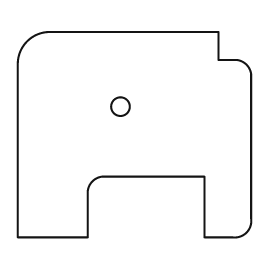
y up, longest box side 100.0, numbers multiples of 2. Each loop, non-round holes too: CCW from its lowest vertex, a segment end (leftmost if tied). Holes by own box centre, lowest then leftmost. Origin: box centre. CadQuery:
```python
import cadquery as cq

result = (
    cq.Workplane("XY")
    .moveTo(-50.0, -44.0)
    .lineTo(-20.0, -44.0)
    .lineTo(-20.0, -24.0)
    .threePointArc((-18.0, -20.0), (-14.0, -18.0))
    .lineTo(30.0, -18.0)
    .lineTo(30.0, -44.0)
    .lineTo(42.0, -44.0)
    .threePointArc((48.0, -42.0), (50.0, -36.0))
    .lineTo(50.0, 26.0)
    .threePointArc((48.0, 30.0), (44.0, 32.0))
    .lineTo(36.0, 32.0)
    .lineTo(36.0, 44.0)
    .lineTo(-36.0, 44.0)
    .threePointArc((-46.0, 40.0), (-50.0, 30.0))
    .close()
    .moveTo(-6.0, 12.0)
    .circle(4.0)
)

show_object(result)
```